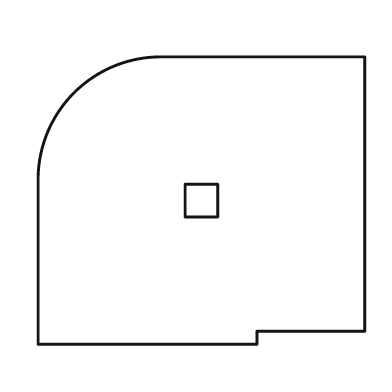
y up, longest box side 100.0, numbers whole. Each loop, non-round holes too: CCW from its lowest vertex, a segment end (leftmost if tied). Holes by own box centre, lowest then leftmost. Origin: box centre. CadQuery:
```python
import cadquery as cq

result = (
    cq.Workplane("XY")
    .moveTo(-50.0, -44.0)
    .lineTo(17.0, -44.0)
    .lineTo(17.0, -40.0)
    .lineTo(50.0, -40.0)
    .lineTo(50.0, 44.0)
    .lineTo(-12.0, 44.0)
    .threePointArc((-39.0, 33.0), (-50.0, 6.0))
    .close()
    .moveTo(-5.0, -5.0)
    .lineTo(5.0, -5.0)
    .lineTo(5.0, 5.0)
    .lineTo(-5.0, 5.0)
    .close()
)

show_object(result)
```